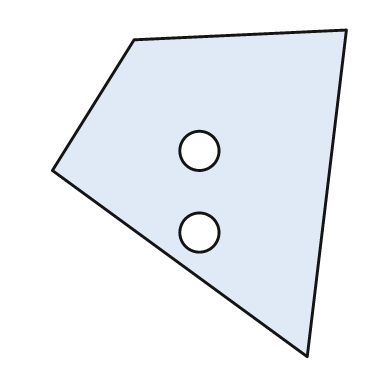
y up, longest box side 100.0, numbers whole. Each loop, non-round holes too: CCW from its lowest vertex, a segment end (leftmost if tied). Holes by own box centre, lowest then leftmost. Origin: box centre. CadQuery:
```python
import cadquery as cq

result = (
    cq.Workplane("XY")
    .moveTo(33.0, -50.0)
    .lineTo(45.0, 50.0)
    .lineTo(-20.0, 47.0)
    .lineTo(-45.0, 7.0)
    .close()
    .moveTo(0.0, -12.0)
    .circle(6.0)
    .moveTo(0.0, 13.0)
    .circle(6.0)
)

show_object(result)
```